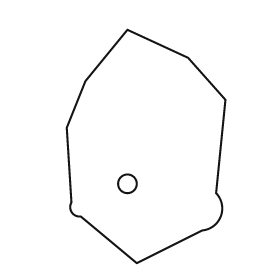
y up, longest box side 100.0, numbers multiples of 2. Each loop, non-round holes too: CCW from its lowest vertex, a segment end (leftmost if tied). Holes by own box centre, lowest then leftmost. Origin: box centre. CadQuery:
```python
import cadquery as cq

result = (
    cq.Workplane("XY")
    .moveTo(-4.0, -50.0)
    .lineTo(24.0, -36.0)
    .threePointArc((32.0, -30.0), (30.0, -20.0))
    .lineTo(34.0, 20.0)
    .lineTo(18.0, 38.0)
    .lineTo(-8.0, 50.0)
    .lineTo(-26.0, 28.0)
    .lineTo(-34.0, 8.0)
    .lineTo(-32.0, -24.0)
    .threePointArc((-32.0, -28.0), (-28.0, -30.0))
    .close()
    .moveTo(-8.0, -16.0)
    .circle(4.0)
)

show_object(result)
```